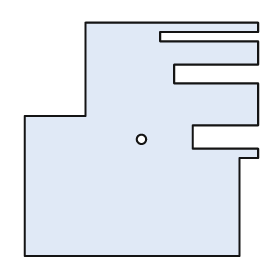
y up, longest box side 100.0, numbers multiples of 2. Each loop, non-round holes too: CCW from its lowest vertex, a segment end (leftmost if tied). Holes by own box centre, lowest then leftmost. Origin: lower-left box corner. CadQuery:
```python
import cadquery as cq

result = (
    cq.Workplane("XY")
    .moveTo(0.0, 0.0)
    .lineTo(92.0, 0.0)
    .lineTo(92.0, 42.0)
    .lineTo(100.0, 42.0)
    .lineTo(100.0, 46.0)
    .lineTo(72.0, 46.0)
    .lineTo(72.0, 56.0)
    .lineTo(100.0, 56.0)
    .lineTo(100.0, 74.0)
    .lineTo(64.0, 74.0)
    .lineTo(64.0, 82.0)
    .lineTo(100.0, 82.0)
    .lineTo(100.0, 92.0)
    .lineTo(58.0, 92.0)
    .lineTo(58.0, 96.0)
    .lineTo(100.0, 96.0)
    .lineTo(100.0, 100.0)
    .lineTo(26.0, 100.0)
    .lineTo(26.0, 60.0)
    .lineTo(0.0, 60.0)
    .close()
    .moveTo(50.0, 50.0)
    .circle(2.0)
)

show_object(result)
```